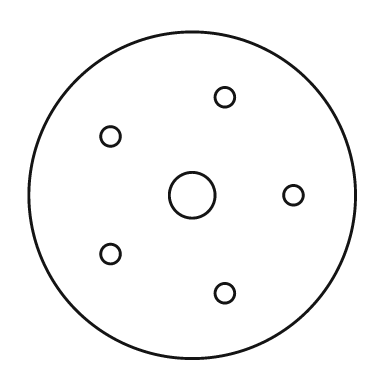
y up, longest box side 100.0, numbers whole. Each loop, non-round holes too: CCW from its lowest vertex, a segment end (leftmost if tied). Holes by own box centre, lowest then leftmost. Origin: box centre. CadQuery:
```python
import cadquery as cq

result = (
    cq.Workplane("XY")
    .moveTo(0.0, 0.0)
    .circle(50.0)
    .moveTo(10.0, -30.0)
    .circle(3.0)
    .moveTo(-25.0, -18.0)
    .circle(3.0)
    .moveTo(0.0, 0.0)
    .circle(7.0)
    .moveTo(31.0, 0.0)
    .circle(3.0)
    .moveTo(-25.0, 18.0)
    .circle(3.0)
    .moveTo(10.0, 30.0)
    .circle(3.0)
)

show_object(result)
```